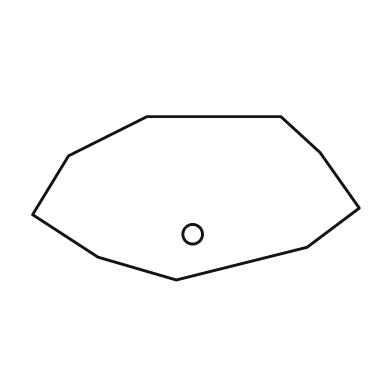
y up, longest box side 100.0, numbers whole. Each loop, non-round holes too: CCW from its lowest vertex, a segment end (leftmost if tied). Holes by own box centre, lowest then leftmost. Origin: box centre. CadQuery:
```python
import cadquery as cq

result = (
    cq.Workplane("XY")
    .moveTo(-6.0, -25.0)
    .lineTo(34.0, -15.0)
    .lineTo(50.0, -3.0)
    .lineTo(38.0, 14.0)
    .lineTo(26.0, 25.0)
    .lineTo(-15.0, 25.0)
    .lineTo(-39.0, 13.0)
    .lineTo(-50.0, -5.0)
    .lineTo(-30.0, -18.0)
    .close()
    .moveTo(-1.0, -11.0)
    .circle(3.0)
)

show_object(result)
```